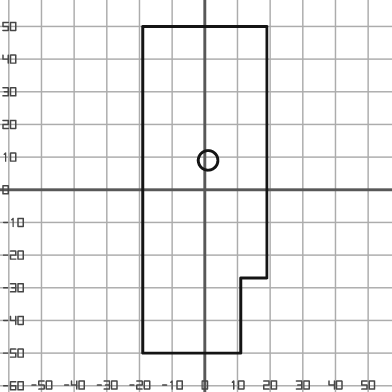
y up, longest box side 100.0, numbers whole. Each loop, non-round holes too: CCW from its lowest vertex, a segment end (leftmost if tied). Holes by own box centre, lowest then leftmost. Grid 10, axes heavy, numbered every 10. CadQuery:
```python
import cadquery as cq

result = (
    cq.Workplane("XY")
    .moveTo(-19.0, -50.0)
    .lineTo(11.0, -50.0)
    .lineTo(11.0, -27.0)
    .lineTo(19.0, -27.0)
    .lineTo(19.0, 50.0)
    .lineTo(-19.0, 50.0)
    .close()
    .moveTo(1.0, 9.0)
    .circle(3.0)
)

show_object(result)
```